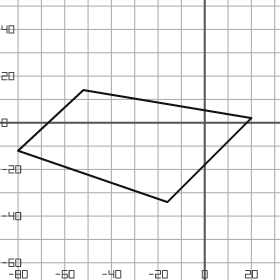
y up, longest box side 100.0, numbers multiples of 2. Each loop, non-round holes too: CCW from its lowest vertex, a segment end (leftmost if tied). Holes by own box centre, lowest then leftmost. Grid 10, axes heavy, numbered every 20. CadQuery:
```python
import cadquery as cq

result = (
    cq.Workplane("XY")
    .moveTo(-16.0, -34.0)
    .lineTo(20.0, 2.0)
    .lineTo(-52.0, 14.0)
    .lineTo(-80.0, -12.0)
    .close()
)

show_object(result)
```